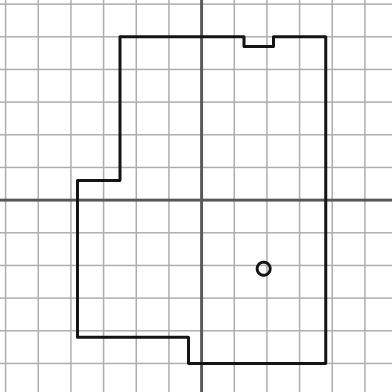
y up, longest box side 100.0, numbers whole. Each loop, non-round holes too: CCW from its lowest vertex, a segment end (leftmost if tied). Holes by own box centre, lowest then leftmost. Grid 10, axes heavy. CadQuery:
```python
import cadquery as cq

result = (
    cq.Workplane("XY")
    .moveTo(-4.0, -50.0)
    .lineTo(38.0, -50.0)
    .lineTo(38.0, 50.0)
    .lineTo(22.0, 50.0)
    .lineTo(22.0, 47.0)
    .lineTo(13.0, 47.0)
    .lineTo(13.0, 50.0)
    .lineTo(-25.0, 50.0)
    .lineTo(-25.0, 6.0)
    .lineTo(-38.0, 6.0)
    .lineTo(-38.0, -42.0)
    .lineTo(-4.0, -42.0)
    .close()
    .moveTo(19.0, -21.0)
    .circle(2.0)
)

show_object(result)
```